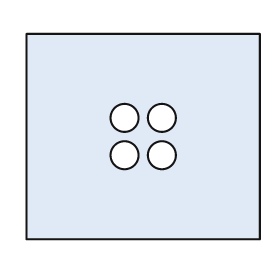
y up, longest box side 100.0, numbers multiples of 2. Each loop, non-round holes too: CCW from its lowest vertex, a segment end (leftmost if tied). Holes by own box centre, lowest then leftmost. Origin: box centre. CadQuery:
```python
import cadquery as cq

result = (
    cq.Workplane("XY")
    .moveTo(-50.0, -44.0)
    .lineTo(50.0, -44.0)
    .lineTo(50.0, 44.0)
    .lineTo(-50.0, 44.0)
    .close()
    .moveTo(-8.0, -8.0)
    .circle(6.0)
    .moveTo(8.0, -8.0)
    .circle(6.0)
    .moveTo(-8.0, 8.0)
    .circle(6.0)
    .moveTo(8.0, 8.0)
    .circle(6.0)
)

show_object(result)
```